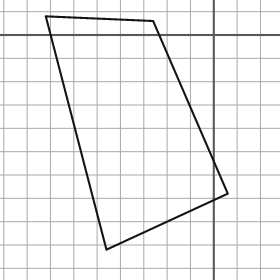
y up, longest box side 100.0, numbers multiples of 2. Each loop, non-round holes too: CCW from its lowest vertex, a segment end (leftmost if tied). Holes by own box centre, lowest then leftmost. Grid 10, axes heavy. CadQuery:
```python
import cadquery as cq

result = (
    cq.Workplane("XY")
    .moveTo(-46.0, -92.0)
    .lineTo(6.0, -68.0)
    .lineTo(-26.0, 6.0)
    .lineTo(-72.0, 8.0)
    .close()
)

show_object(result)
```